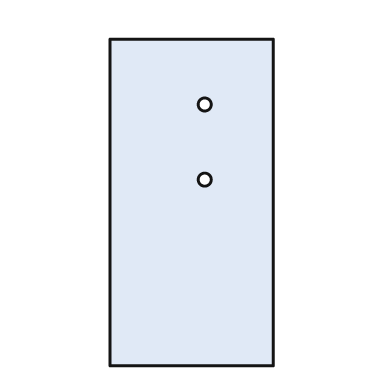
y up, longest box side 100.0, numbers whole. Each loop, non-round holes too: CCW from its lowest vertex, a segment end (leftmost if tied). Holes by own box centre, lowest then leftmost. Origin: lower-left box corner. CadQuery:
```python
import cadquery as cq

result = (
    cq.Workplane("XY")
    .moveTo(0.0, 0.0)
    .lineTo(50.0, 0.0)
    .lineTo(50.0, 100.0)
    .lineTo(0.0, 100.0)
    .close()
    .moveTo(29.0, 57.0)
    .circle(2.0)
    .moveTo(29.0, 80.0)
    .circle(2.0)
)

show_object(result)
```